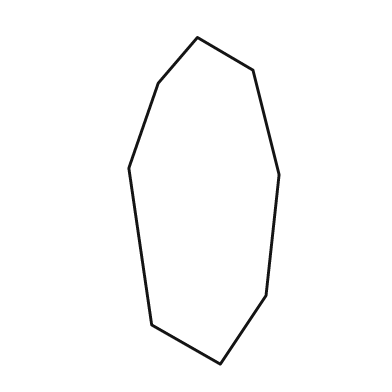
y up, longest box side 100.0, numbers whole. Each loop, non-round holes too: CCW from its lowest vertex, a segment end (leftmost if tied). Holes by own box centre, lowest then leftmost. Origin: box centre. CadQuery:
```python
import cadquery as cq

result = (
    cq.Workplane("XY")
    .moveTo(5.0, -50.0)
    .lineTo(19.0, -29.0)
    .lineTo(23.0, 8.0)
    .lineTo(15.0, 40.0)
    .lineTo(-2.0, 50.0)
    .lineTo(-14.0, 36.0)
    .lineTo(-23.0, 10.0)
    .lineTo(-16.0, -38.0)
    .close()
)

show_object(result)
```